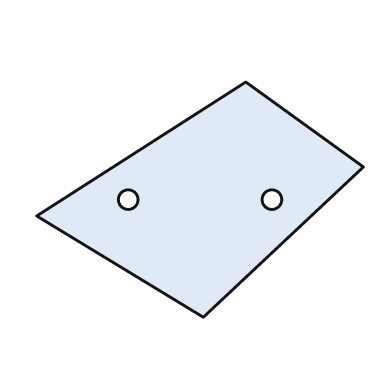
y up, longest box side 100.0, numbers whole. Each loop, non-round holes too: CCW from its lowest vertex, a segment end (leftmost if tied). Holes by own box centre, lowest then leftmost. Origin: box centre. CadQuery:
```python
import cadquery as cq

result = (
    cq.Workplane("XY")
    .moveTo(1.0, -36.0)
    .lineTo(50.0, 10.0)
    .lineTo(14.0, 36.0)
    .lineTo(-50.0, -5.0)
    .close()
    .moveTo(-22.0, 0.0)
    .circle(3.0)
    .moveTo(22.0, 0.0)
    .circle(3.0)
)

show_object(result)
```